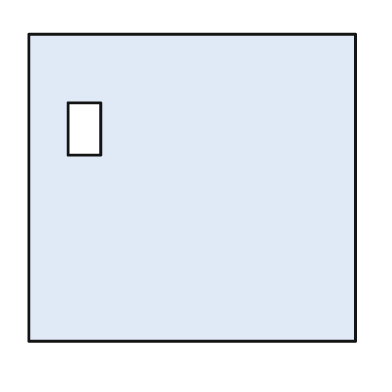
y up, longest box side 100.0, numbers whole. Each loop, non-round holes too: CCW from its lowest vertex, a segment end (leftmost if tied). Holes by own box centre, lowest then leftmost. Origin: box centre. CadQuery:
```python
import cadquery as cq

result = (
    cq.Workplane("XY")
    .moveTo(-50.0, -47.0)
    .lineTo(50.0, -47.0)
    .lineTo(50.0, 47.0)
    .lineTo(-50.0, 47.0)
    .close()
    .moveTo(-38.0, 10.0)
    .lineTo(-28.0, 10.0)
    .lineTo(-28.0, 26.0)
    .lineTo(-38.0, 26.0)
    .close()
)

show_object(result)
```